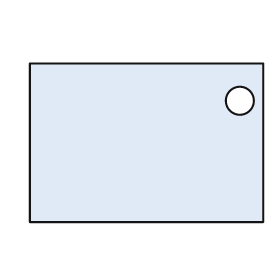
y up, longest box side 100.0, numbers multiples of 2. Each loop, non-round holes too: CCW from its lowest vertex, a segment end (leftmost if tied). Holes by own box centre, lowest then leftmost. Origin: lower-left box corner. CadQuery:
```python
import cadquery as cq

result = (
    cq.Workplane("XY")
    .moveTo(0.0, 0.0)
    .lineTo(100.0, 0.0)
    .lineTo(100.0, 68.0)
    .lineTo(0.0, 68.0)
    .close()
    .moveTo(90.0, 52.0)
    .circle(6.0)
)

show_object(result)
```